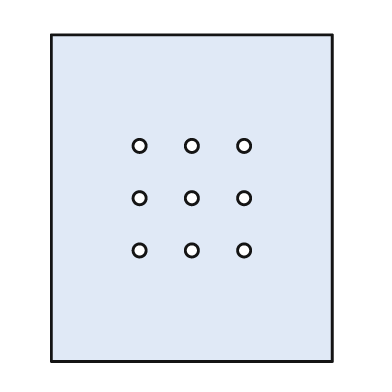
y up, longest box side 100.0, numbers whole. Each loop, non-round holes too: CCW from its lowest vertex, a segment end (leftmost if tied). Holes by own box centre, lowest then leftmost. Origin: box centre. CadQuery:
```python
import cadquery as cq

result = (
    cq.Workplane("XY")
    .moveTo(-43.0, -50.0)
    .lineTo(43.0, -50.0)
    .lineTo(43.0, 50.0)
    .lineTo(-43.0, 50.0)
    .close()
    .moveTo(-16.0, -16.0)
    .circle(2.0)
    .moveTo(0.0, -16.0)
    .circle(2.0)
    .moveTo(16.0, -16.0)
    .circle(2.0)
    .moveTo(-16.0, 0.0)
    .circle(2.0)
    .moveTo(0.0, 0.0)
    .circle(2.0)
    .moveTo(16.0, 0.0)
    .circle(2.0)
    .moveTo(-16.0, 16.0)
    .circle(2.0)
    .moveTo(0.0, 16.0)
    .circle(2.0)
    .moveTo(16.0, 16.0)
    .circle(2.0)
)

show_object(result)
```